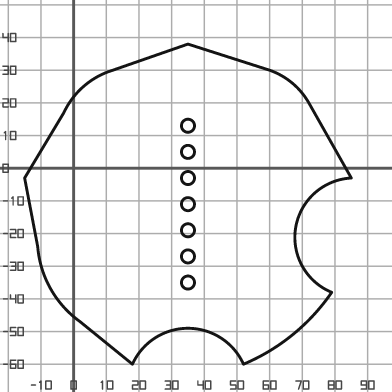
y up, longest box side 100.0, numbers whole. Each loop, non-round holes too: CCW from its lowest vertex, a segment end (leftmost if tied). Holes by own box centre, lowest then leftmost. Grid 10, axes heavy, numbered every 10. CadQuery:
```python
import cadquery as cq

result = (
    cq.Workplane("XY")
    .moveTo(18.0, -60.0)
    .threePointArc((35.0, -49.0), (52.0, -60.0))
    .threePointArc((67.0, -51.0), (79.0, -38.0))
    .threePointArc((68.0, -18.0), (85.0, -3.0))
    .lineTo(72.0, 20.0)
    .threePointArc((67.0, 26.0), (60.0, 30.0))
    .lineTo(35.0, 38.0)
    .lineTo(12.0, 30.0)
    .threePointArc((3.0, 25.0), (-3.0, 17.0))
    .lineTo(-15.0, -3.0)
    .lineTo(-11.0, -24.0)
    .threePointArc((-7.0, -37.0), (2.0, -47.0))
    .close()
    .moveTo(35.0, -35.0)
    .circle(2.0)
    .moveTo(35.0, -27.0)
    .circle(2.0)
    .moveTo(35.0, -19.0)
    .circle(2.0)
    .moveTo(35.0, -11.0)
    .circle(2.0)
    .moveTo(35.0, -3.0)
    .circle(2.0)
    .moveTo(35.0, 5.0)
    .circle(2.0)
    .moveTo(35.0, 13.0)
    .circle(2.0)
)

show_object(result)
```